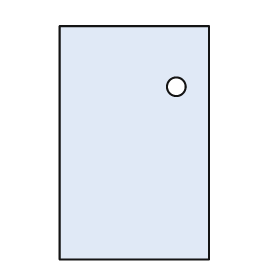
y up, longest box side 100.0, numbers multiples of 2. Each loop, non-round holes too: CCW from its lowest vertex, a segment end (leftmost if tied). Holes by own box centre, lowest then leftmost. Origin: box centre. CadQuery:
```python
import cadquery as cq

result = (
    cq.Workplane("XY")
    .moveTo(-32.0, -50.0)
    .lineTo(32.0, -50.0)
    .lineTo(32.0, 50.0)
    .lineTo(-32.0, 50.0)
    .close()
    .moveTo(18.0, 24.0)
    .circle(4.0)
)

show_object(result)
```